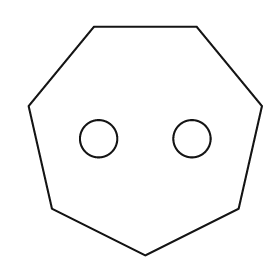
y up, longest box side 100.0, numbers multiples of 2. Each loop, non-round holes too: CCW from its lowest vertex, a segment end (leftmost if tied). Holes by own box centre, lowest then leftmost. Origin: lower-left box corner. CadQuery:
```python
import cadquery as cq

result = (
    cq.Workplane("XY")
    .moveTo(50.0, 0.0)
    .lineTo(90.0, 20.0)
    .lineTo(100.0, 64.0)
    .lineTo(72.0, 98.0)
    .lineTo(28.0, 98.0)
    .lineTo(0.0, 64.0)
    .lineTo(10.0, 20.0)
    .close()
    .moveTo(30.0, 50.0)
    .circle(8.0)
    .moveTo(70.0, 50.0)
    .circle(8.0)
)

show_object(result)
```